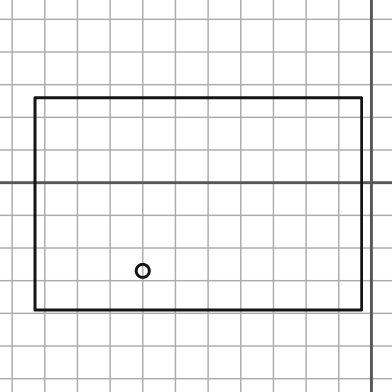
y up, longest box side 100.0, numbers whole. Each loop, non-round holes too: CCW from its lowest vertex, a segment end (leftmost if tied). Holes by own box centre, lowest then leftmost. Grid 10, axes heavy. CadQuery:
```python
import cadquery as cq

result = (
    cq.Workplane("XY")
    .moveTo(-103.0, -39.0)
    .lineTo(-3.0, -39.0)
    .lineTo(-3.0, 26.0)
    .lineTo(-103.0, 26.0)
    .close()
    .moveTo(-70.0, -27.0)
    .circle(2.0)
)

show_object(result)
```